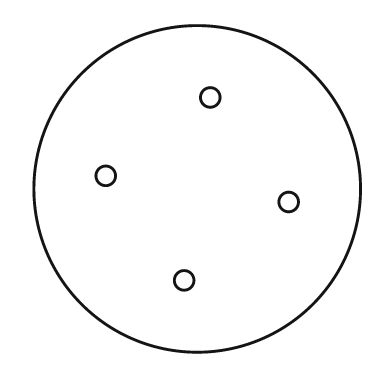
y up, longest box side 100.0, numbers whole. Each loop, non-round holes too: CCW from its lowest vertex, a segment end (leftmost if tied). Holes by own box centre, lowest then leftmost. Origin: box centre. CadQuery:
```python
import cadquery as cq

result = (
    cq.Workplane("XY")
    .moveTo(0.0, 0.0)
    .circle(50.0)
    .moveTo(-4.0, -28.0)
    .circle(3.0)
    .moveTo(28.0, -4.0)
    .circle(3.0)
    .moveTo(-28.0, 4.0)
    .circle(3.0)
    .moveTo(4.0, 28.0)
    .circle(3.0)
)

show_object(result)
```